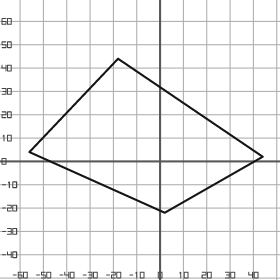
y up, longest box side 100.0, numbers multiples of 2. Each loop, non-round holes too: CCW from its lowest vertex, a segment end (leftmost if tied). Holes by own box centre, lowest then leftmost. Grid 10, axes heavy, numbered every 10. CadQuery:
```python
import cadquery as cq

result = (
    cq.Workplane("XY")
    .moveTo(2.0, -22.0)
    .lineTo(44.0, 2.0)
    .lineTo(-18.0, 44.0)
    .lineTo(-56.0, 4.0)
    .close()
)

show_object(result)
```